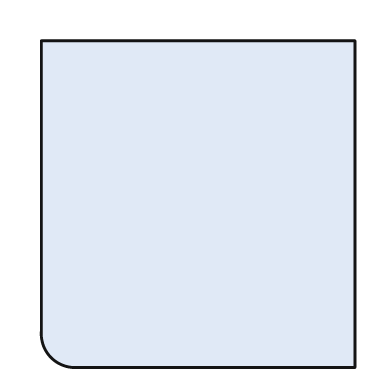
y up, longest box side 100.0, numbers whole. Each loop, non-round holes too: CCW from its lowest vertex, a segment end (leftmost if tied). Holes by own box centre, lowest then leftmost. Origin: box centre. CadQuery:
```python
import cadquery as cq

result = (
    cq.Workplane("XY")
    .moveTo(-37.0, -50.0)
    .lineTo(48.0, -50.0)
    .lineTo(48.0, 50.0)
    .lineTo(-48.0, 50.0)
    .lineTo(-48.0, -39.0)
    .threePointArc((-45.0, -47.0), (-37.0, -50.0))
    .close()
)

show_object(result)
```